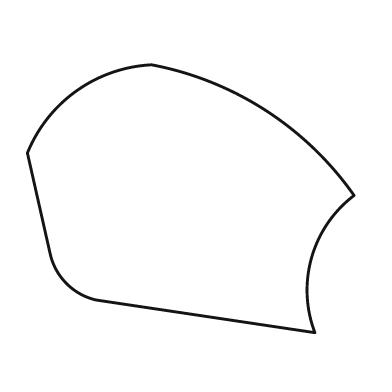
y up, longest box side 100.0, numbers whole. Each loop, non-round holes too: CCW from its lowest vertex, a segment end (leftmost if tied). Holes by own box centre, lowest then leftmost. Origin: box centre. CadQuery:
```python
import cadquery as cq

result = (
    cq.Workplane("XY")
    .moveTo(38.0, -41.0)
    .threePointArc((37.0, -18.0), (50.0, 1.0))
    .threePointArc((23.0, 27.0), (-12.0, 41.0))
    .threePointArc((-35.0, 33.0), (-50.0, 14.0))
    .lineTo(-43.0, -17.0)
    .threePointArc((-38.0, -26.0), (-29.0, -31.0))
    .close()
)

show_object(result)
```